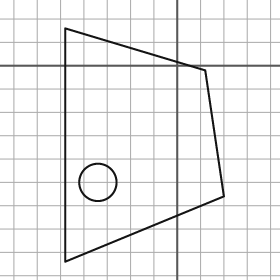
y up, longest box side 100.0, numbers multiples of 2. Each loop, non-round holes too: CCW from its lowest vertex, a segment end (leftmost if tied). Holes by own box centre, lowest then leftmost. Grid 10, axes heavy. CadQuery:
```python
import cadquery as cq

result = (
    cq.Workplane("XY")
    .moveTo(-48.0, -84.0)
    .lineTo(20.0, -56.0)
    .lineTo(12.0, -2.0)
    .lineTo(-48.0, 16.0)
    .close()
    .moveTo(-34.0, -50.0)
    .circle(8.0)
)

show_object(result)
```